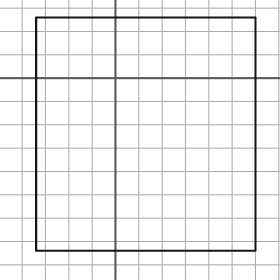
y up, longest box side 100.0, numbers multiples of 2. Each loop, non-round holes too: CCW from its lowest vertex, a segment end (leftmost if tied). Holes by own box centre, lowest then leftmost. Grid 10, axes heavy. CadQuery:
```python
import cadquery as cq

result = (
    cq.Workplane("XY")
    .moveTo(-34.0, -74.0)
    .lineTo(60.0, -74.0)
    .lineTo(60.0, 26.0)
    .lineTo(-34.0, 26.0)
    .close()
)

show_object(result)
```